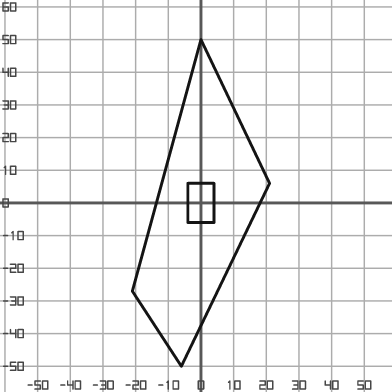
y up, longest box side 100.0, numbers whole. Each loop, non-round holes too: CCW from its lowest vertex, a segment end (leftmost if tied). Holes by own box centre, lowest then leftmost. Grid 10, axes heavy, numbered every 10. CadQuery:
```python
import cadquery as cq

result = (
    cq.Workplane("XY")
    .moveTo(-6.0, -50.0)
    .lineTo(21.0, 6.0)
    .lineTo(0.0, 50.0)
    .lineTo(-21.0, -27.0)
    .close()
    .moveTo(-4.0, -6.0)
    .lineTo(4.0, -6.0)
    .lineTo(4.0, 6.0)
    .lineTo(-4.0, 6.0)
    .close()
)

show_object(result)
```